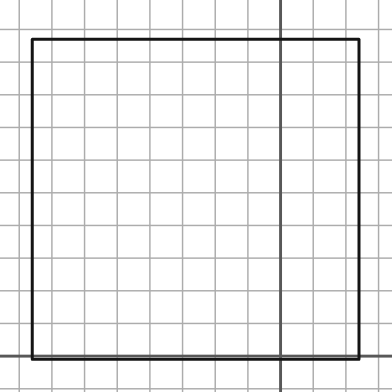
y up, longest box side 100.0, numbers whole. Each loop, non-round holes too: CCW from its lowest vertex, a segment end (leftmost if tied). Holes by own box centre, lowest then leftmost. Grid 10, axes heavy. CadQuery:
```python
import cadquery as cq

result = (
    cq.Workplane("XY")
    .moveTo(-76.0, -1.0)
    .lineTo(24.0, -1.0)
    .lineTo(24.0, 97.0)
    .lineTo(-76.0, 97.0)
    .close()
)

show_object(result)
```